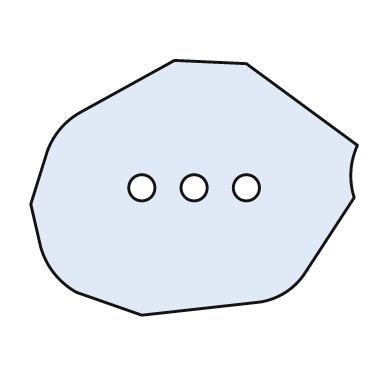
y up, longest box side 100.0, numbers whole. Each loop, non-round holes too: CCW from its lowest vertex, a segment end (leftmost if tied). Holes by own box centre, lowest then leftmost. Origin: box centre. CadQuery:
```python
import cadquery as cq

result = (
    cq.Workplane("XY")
    .moveTo(-16.0, -39.0)
    .lineTo(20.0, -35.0)
    .threePointArc((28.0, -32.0), (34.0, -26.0))
    .lineTo(49.0, -3.0)
    .threePointArc((48.0, 5.0), (50.0, 13.0))
    .lineTo(16.0, 38.0)
    .lineTo(-6.0, 39.0)
    .lineTo(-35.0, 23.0)
    .threePointArc((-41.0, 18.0), (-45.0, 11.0))
    .lineTo(-50.0, -5.0)
    .lineTo(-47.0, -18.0)
    .threePointArc((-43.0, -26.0), (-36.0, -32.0))
    .close()
    .moveTo(-16.0, 0.0)
    .circle(4.0)
    .moveTo(0.0, 0.0)
    .circle(4.0)
    .moveTo(16.0, 0.0)
    .circle(4.0)
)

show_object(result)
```